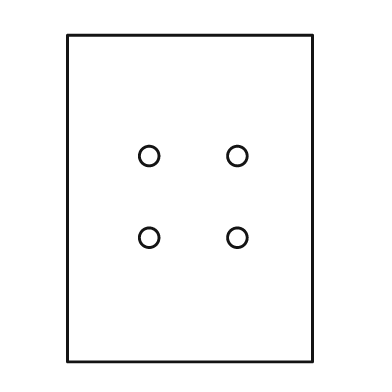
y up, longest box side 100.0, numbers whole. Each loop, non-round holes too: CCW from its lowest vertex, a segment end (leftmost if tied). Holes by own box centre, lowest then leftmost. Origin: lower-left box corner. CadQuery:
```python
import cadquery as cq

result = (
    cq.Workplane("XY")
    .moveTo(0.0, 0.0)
    .lineTo(75.0, 0.0)
    .lineTo(75.0, 100.0)
    .lineTo(0.0, 100.0)
    .close()
    .moveTo(25.0, 38.0)
    .circle(3.0)
    .moveTo(52.0, 38.0)
    .circle(3.0)
    .moveTo(25.0, 63.0)
    .circle(3.0)
    .moveTo(52.0, 63.0)
    .circle(3.0)
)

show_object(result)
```